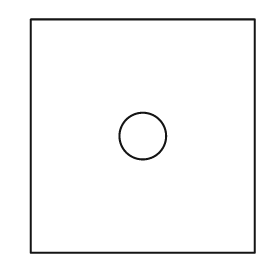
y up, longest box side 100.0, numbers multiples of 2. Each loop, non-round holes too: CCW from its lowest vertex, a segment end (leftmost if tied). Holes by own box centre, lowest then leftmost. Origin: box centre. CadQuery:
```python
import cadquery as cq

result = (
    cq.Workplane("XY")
    .moveTo(-48.0, -50.0)
    .lineTo(48.0, -50.0)
    .lineTo(48.0, 50.0)
    .lineTo(-48.0, 50.0)
    .close()
    .moveTo(0.0, 0.0)
    .circle(10.0)
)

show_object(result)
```